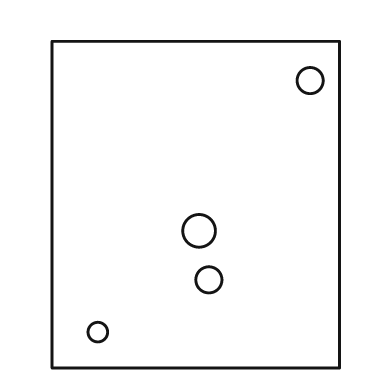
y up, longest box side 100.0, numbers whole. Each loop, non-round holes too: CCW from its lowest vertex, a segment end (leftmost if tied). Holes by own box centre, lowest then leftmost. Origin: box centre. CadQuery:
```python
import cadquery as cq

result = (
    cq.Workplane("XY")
    .moveTo(-44.0, -50.0)
    .lineTo(44.0, -50.0)
    .lineTo(44.0, 50.0)
    .lineTo(-44.0, 50.0)
    .close()
    .moveTo(-30.0, -39.0)
    .circle(3.0)
    .moveTo(4.0, -23.0)
    .circle(4.0)
    .moveTo(1.0, -8.0)
    .circle(5.0)
    .moveTo(35.0, 38.0)
    .circle(4.0)
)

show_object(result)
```